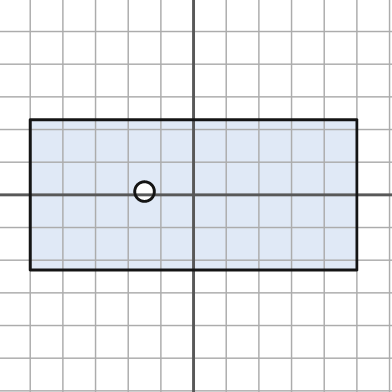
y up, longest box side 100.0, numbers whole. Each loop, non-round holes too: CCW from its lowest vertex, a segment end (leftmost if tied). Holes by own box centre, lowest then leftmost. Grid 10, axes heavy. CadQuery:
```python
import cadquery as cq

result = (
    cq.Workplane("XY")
    .moveTo(-50.0, -23.0)
    .lineTo(50.0, -23.0)
    .lineTo(50.0, 23.0)
    .lineTo(-50.0, 23.0)
    .close()
    .moveTo(-15.0, 1.0)
    .circle(3.0)
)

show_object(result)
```